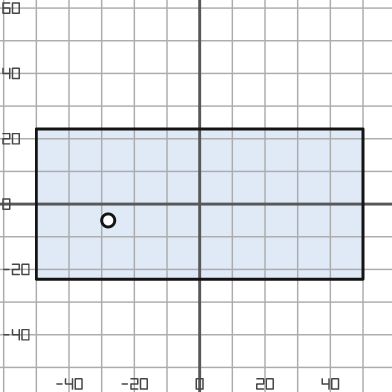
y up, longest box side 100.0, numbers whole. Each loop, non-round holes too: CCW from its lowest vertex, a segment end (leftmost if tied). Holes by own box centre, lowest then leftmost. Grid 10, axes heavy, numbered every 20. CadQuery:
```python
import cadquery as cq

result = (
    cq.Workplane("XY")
    .moveTo(-50.0, -23.0)
    .lineTo(50.0, -23.0)
    .lineTo(50.0, 23.0)
    .lineTo(-50.0, 23.0)
    .close()
    .moveTo(-28.0, -5.0)
    .circle(2.0)
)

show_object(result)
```